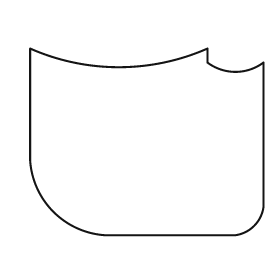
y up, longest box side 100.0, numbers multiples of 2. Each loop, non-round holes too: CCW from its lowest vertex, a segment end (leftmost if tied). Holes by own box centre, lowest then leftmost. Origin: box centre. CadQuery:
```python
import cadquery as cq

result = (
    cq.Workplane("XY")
    .moveTo(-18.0, -40.0)
    .lineTo(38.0, -40.0)
    .threePointArc((46.0, -36.0), (50.0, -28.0))
    .lineTo(50.0, 34.0)
    .threePointArc((38.0, 30.0), (26.0, 34.0))
    .lineTo(26.0, 40.0)
    .threePointArc((-12.0, 32.0), (-50.0, 40.0))
    .lineTo(-50.0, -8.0)
    .threePointArc((-40.0, -30.0), (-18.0, -40.0))
    .close()
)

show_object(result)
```